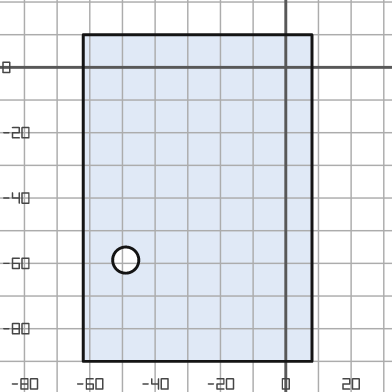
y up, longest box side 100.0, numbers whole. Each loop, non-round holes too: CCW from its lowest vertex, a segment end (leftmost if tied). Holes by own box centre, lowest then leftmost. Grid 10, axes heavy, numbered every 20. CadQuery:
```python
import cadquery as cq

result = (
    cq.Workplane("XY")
    .moveTo(-62.0, -90.0)
    .lineTo(8.0, -90.0)
    .lineTo(8.0, 10.0)
    .lineTo(-62.0, 10.0)
    .close()
    .moveTo(-49.0, -59.0)
    .circle(4.0)
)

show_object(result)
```